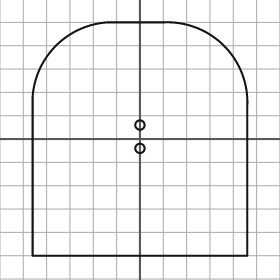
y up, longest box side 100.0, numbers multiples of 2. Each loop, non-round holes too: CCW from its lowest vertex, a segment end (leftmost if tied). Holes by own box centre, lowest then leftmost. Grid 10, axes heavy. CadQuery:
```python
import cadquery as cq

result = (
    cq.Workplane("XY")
    .moveTo(-46.0, -50.0)
    .lineTo(46.0, -50.0)
    .lineTo(46.0, 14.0)
    .threePointArc((36.0, 40.0), (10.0, 50.0))
    .lineTo(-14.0, 50.0)
    .threePointArc((-36.0, 40.0), (-46.0, 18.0))
    .close()
    .moveTo(0.0, -4.0)
    .circle(2.0)
    .moveTo(0.0, 6.0)
    .circle(2.0)
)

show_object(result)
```